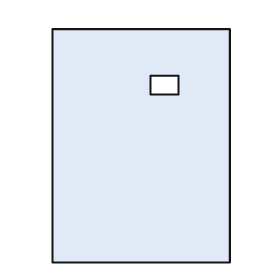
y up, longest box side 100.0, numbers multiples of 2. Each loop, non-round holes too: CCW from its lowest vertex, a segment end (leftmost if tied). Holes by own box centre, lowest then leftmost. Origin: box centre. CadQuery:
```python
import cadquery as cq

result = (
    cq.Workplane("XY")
    .moveTo(-38.0, -50.0)
    .lineTo(38.0, -50.0)
    .lineTo(38.0, 50.0)
    .lineTo(-38.0, 50.0)
    .close()
    .moveTo(4.0, 22.0)
    .lineTo(16.0, 22.0)
    .lineTo(16.0, 30.0)
    .lineTo(4.0, 30.0)
    .close()
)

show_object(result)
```